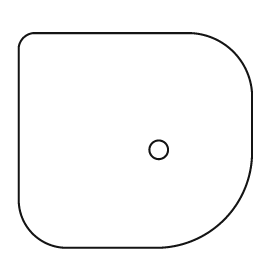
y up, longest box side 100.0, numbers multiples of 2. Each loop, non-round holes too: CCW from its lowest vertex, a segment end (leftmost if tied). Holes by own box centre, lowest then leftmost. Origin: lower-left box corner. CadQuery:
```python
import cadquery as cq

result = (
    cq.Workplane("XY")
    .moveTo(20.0, 0.0)
    .lineTo(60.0, 0.0)
    .threePointArc((88.0, 12.0), (100.0, 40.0))
    .lineTo(100.0, 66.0)
    .threePointArc((92.0, 84.0), (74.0, 92.0))
    .lineTo(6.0, 92.0)
    .threePointArc((2.0, 90.0), (0.0, 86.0))
    .lineTo(0.0, 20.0)
    .threePointArc((6.0, 6.0), (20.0, 0.0))
    .close()
    .moveTo(60.0, 42.0)
    .circle(4.0)
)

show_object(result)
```